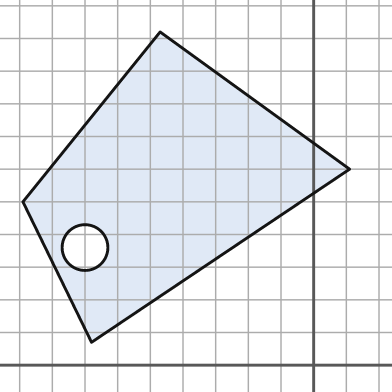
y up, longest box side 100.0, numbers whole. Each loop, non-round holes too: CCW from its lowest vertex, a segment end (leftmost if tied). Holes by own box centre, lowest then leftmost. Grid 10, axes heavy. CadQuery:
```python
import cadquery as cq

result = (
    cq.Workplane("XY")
    .moveTo(-68.0, 7.0)
    .lineTo(11.0, 60.0)
    .lineTo(-47.0, 102.0)
    .lineTo(-89.0, 50.0)
    .close()
    .moveTo(-70.0, 36.0)
    .circle(7.0)
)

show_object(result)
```